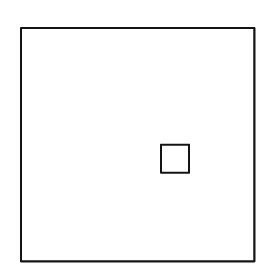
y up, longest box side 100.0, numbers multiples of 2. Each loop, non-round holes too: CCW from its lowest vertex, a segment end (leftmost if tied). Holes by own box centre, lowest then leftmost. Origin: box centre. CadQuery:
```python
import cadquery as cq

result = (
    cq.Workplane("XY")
    .moveTo(-50.0, -50.0)
    .lineTo(50.0, -50.0)
    .lineTo(50.0, 50.0)
    .lineTo(-50.0, 50.0)
    .close()
    .moveTo(10.0, -12.0)
    .lineTo(22.0, -12.0)
    .lineTo(22.0, 0.0)
    .lineTo(10.0, 0.0)
    .close()
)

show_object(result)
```